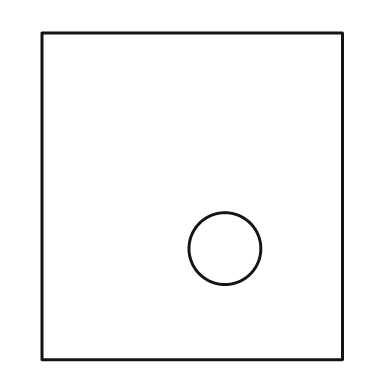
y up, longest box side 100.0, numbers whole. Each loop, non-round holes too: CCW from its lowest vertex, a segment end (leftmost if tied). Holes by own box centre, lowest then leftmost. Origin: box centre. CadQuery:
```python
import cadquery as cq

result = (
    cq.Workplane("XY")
    .moveTo(-46.0, -50.0)
    .lineTo(46.0, -50.0)
    .lineTo(46.0, 50.0)
    .lineTo(-46.0, 50.0)
    .close()
    .moveTo(10.0, -16.0)
    .circle(11.0)
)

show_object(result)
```